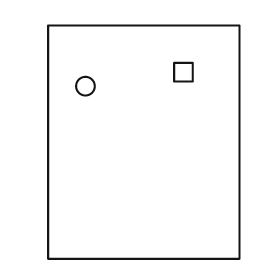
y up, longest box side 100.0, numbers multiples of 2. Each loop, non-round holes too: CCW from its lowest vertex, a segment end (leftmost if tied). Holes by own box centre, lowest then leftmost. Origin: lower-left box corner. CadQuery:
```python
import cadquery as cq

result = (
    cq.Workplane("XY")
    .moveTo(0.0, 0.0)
    .lineTo(82.0, 0.0)
    .lineTo(82.0, 100.0)
    .lineTo(0.0, 100.0)
    .close()
    .moveTo(16.0, 74.0)
    .circle(4.0)
    .moveTo(54.0, 76.0)
    .lineTo(62.0, 76.0)
    .lineTo(62.0, 84.0)
    .lineTo(54.0, 84.0)
    .close()
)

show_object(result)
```